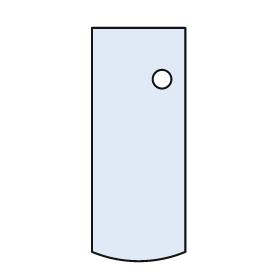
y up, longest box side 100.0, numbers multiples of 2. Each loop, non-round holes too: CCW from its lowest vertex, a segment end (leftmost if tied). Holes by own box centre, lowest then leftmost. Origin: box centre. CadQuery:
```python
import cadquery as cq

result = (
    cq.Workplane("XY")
    .moveTo(-20.0, -46.0)
    .threePointArc((0.0, -50.0), (20.0, -46.0))
    .lineTo(20.0, 50.0)
    .lineTo(-20.0, 50.0)
    .close()
    .moveTo(10.0, 28.0)
    .circle(4.0)
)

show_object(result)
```